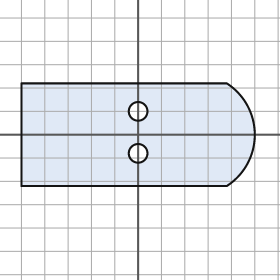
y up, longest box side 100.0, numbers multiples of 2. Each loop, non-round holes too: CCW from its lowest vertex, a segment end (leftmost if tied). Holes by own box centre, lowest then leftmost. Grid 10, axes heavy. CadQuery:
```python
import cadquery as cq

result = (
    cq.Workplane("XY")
    .moveTo(-50.0, -22.0)
    .lineTo(38.0, -22.0)
    .threePointArc((50.0, 0.0), (38.0, 22.0))
    .lineTo(-50.0, 22.0)
    .close()
    .moveTo(0.0, -8.0)
    .circle(4.0)
    .moveTo(0.0, 10.0)
    .circle(4.0)
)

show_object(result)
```